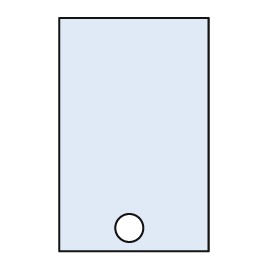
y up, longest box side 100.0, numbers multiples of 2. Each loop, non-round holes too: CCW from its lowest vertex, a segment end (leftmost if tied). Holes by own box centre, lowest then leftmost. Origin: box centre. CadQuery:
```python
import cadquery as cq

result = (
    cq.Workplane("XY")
    .moveTo(-32.0, -50.0)
    .lineTo(32.0, -50.0)
    .lineTo(32.0, 50.0)
    .lineTo(-32.0, 50.0)
    .close()
    .moveTo(-2.0, -40.0)
    .circle(6.0)
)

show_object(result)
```